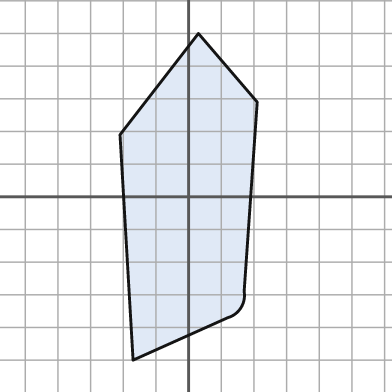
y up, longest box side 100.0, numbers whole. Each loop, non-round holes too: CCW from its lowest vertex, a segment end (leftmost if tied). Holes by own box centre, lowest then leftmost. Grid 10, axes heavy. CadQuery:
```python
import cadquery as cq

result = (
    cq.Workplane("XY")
    .moveTo(-17.0, -50.0)
    .lineTo(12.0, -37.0)
    .threePointArc((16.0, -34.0), (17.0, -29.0))
    .lineTo(21.0, 29.0)
    .lineTo(3.0, 50.0)
    .lineTo(-21.0, 19.0)
    .close()
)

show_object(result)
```